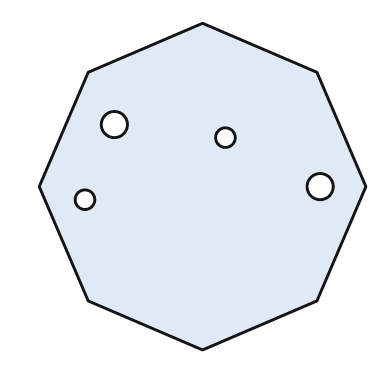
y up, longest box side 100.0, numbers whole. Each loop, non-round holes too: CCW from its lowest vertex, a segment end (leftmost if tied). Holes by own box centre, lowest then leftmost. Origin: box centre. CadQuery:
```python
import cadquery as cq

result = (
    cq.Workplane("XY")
    .moveTo(0.0, -50.0)
    .lineTo(35.0, -35.0)
    .lineTo(50.0, 0.0)
    .lineTo(35.0, 35.0)
    .lineTo(0.0, 50.0)
    .lineTo(-35.0, 35.0)
    .lineTo(-50.0, 0.0)
    .lineTo(-35.0, -35.0)
    .close()
    .moveTo(-36.0, -4.0)
    .circle(3.0)
    .moveTo(36.0, 0.0)
    .circle(4.0)
    .moveTo(7.0, 15.0)
    .circle(3.0)
    .moveTo(-27.0, 19.0)
    .circle(4.0)
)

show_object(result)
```